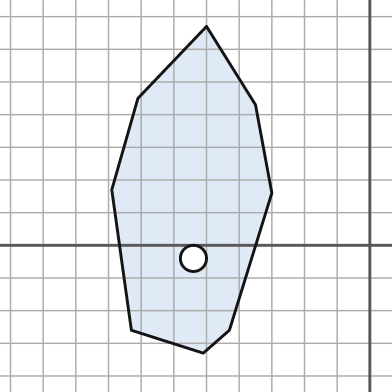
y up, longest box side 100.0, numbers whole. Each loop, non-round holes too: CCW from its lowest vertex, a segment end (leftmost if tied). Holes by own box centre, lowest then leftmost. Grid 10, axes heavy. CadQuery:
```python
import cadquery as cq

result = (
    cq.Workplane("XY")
    .moveTo(-51.0, -33.0)
    .lineTo(-43.0, -26.0)
    .lineTo(-30.0, 16.0)
    .lineTo(-35.0, 43.0)
    .lineTo(-50.0, 67.0)
    .lineTo(-71.0, 45.0)
    .lineTo(-79.0, 17.0)
    .lineTo(-73.0, -26.0)
    .close()
    .moveTo(-54.0, -4.0)
    .circle(4.0)
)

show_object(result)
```